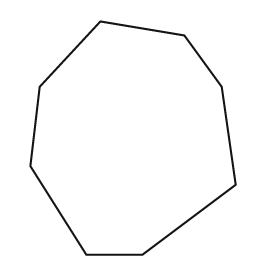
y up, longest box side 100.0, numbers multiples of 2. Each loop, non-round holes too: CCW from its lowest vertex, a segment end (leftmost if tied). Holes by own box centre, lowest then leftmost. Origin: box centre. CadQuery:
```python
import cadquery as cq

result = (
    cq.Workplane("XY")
    .moveTo(-20.0, -50.0)
    .lineTo(4.0, -50.0)
    .lineTo(44.0, -20.0)
    .lineTo(38.0, 22.0)
    .lineTo(22.0, 44.0)
    .lineTo(-14.0, 50.0)
    .lineTo(-40.0, 22.0)
    .lineTo(-44.0, -12.0)
    .close()
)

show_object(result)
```